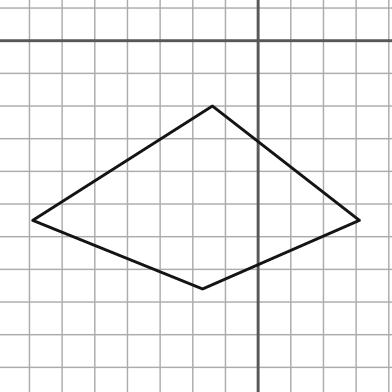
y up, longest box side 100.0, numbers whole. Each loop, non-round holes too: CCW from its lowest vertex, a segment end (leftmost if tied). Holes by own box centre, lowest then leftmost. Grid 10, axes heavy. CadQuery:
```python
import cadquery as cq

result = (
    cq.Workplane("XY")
    .moveTo(-17.0, -76.0)
    .lineTo(31.0, -55.0)
    .lineTo(-14.0, -20.0)
    .lineTo(-69.0, -55.0)
    .close()
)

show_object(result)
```